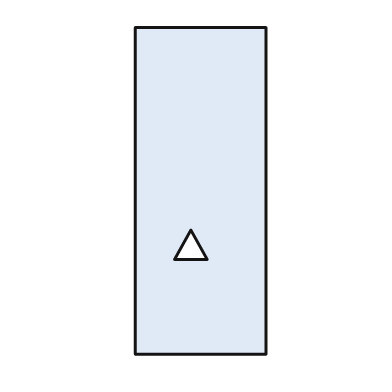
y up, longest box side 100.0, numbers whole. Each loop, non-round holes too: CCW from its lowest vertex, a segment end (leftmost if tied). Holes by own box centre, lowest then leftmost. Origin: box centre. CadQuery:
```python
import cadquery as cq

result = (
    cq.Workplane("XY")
    .moveTo(-20.0, -50.0)
    .lineTo(20.0, -50.0)
    .lineTo(20.0, 50.0)
    .lineTo(-20.0, 50.0)
    .close()
    .moveTo(-8.0, -21.0)
    .lineTo(2.0, -21.0)
    .lineTo(-3.0, -12.0)
    .close()
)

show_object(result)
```